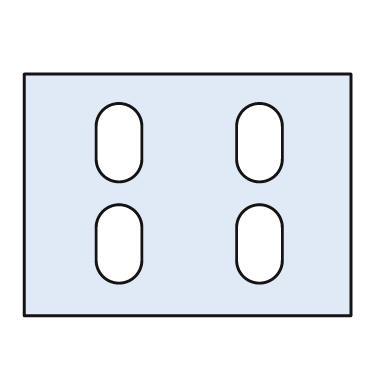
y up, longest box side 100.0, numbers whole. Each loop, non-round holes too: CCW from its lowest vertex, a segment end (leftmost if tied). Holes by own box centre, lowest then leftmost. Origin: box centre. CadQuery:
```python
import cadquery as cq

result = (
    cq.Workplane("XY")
    .moveTo(-50.0, -37.0)
    .lineTo(50.0, -37.0)
    .lineTo(50.0, 37.0)
    .lineTo(-50.0, 37.0)
    .close()
    .moveTo(-28.0, -20.0)
    .threePointArc((-21.0, -27.0), (-14.0, -20.0))
    .lineTo(-14.0, -10.0)
    .threePointArc((-21.0, -3.0), (-28.0, -10.0))
    .close()
    .moveTo(15.0, -20.0)
    .threePointArc((22.0, -27.0), (29.0, -20.0))
    .lineTo(29.0, -10.0)
    .threePointArc((22.0, -3.0), (15.0, -10.0))
    .close()
    .moveTo(-28.0, 11.0)
    .threePointArc((-21.0, 4.0), (-14.0, 11.0))
    .lineTo(-14.0, 21.0)
    .threePointArc((-21.0, 28.0), (-28.0, 21.0))
    .close()
    .moveTo(15.0, 11.0)
    .threePointArc((22.0, 4.0), (29.0, 11.0))
    .lineTo(29.0, 21.0)
    .threePointArc((22.0, 28.0), (15.0, 21.0))
    .close()
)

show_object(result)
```